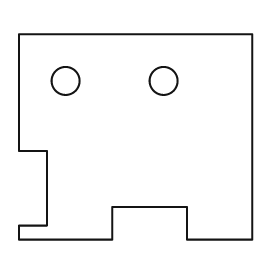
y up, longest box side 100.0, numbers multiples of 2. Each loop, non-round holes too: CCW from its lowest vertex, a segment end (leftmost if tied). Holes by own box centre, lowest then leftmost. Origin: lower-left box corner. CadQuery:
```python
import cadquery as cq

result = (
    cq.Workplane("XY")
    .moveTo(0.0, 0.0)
    .lineTo(40.0, 0.0)
    .lineTo(40.0, 14.0)
    .lineTo(72.0, 14.0)
    .lineTo(72.0, 0.0)
    .lineTo(100.0, 0.0)
    .lineTo(100.0, 88.0)
    .lineTo(0.0, 88.0)
    .lineTo(0.0, 38.0)
    .lineTo(12.0, 38.0)
    .lineTo(12.0, 6.0)
    .lineTo(0.0, 6.0)
    .close()
    .moveTo(20.0, 68.0)
    .circle(6.0)
    .moveTo(62.0, 68.0)
    .circle(6.0)
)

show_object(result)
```